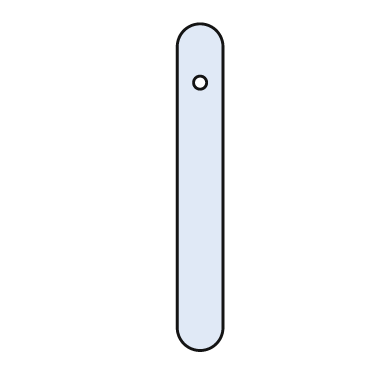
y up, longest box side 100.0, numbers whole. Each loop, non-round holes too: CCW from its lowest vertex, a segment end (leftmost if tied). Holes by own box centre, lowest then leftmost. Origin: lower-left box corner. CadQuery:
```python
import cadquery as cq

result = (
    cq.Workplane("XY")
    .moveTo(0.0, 7.0)
    .threePointArc((7.0, 0.0), (14.0, 7.0))
    .lineTo(14.0, 93.0)
    .threePointArc((7.0, 100.0), (0.0, 93.0))
    .close()
    .moveTo(7.0, 82.0)
    .circle(2.0)
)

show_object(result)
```